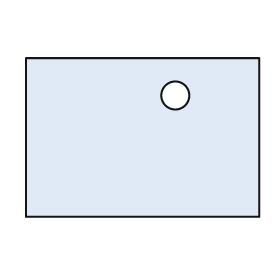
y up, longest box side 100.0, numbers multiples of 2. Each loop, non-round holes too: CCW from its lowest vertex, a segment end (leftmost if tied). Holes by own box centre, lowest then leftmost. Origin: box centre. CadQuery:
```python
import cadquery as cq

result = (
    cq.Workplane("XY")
    .moveTo(-50.0, -34.0)
    .lineTo(50.0, -34.0)
    .lineTo(50.0, 34.0)
    .lineTo(-50.0, 34.0)
    .close()
    .moveTo(14.0, 18.0)
    .circle(6.0)
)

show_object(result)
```